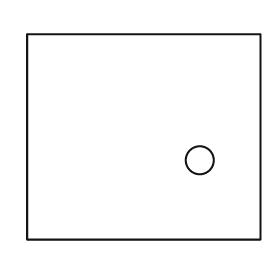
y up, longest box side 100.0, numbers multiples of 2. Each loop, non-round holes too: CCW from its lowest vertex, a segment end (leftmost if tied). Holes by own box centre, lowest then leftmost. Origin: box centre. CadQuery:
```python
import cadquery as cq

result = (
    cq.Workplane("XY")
    .moveTo(-50.0, -44.0)
    .lineTo(50.0, -44.0)
    .lineTo(50.0, 44.0)
    .lineTo(-50.0, 44.0)
    .close()
    .moveTo(24.0, -10.0)
    .circle(6.0)
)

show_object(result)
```